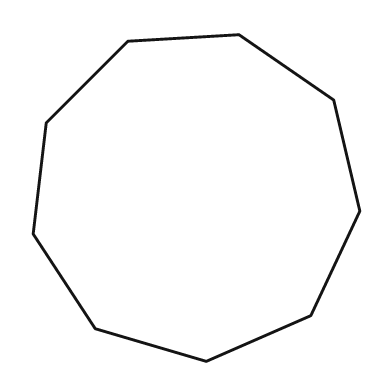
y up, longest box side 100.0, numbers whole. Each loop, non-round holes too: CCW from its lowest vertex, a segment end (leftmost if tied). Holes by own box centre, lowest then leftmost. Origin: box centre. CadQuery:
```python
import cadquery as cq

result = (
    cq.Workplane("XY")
    .moveTo(3.0, -50.0)
    .lineTo(35.0, -36.0)
    .lineTo(50.0, -4.0)
    .lineTo(42.0, 30.0)
    .lineTo(13.0, 50.0)
    .lineTo(-21.0, 48.0)
    .lineTo(-46.0, 23.0)
    .lineTo(-50.0, -11.0)
    .lineTo(-31.0, -40.0)
    .close()
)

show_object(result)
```